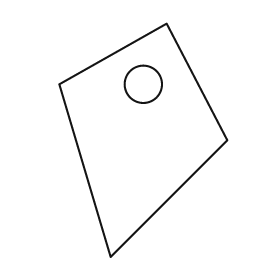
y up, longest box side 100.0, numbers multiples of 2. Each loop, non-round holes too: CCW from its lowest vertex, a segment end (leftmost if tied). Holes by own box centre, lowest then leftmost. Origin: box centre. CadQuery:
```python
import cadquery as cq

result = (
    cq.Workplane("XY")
    .moveTo(-14.0, -50.0)
    .lineTo(36.0, 0.0)
    .lineTo(10.0, 50.0)
    .lineTo(-36.0, 24.0)
    .close()
    .moveTo(0.0, 24.0)
    .circle(8.0)
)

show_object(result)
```